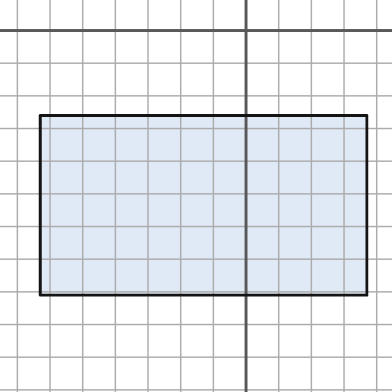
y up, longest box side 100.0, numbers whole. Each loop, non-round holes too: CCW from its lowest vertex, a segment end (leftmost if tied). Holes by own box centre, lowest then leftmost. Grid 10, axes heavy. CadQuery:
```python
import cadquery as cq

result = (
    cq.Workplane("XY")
    .moveTo(-63.0, -81.0)
    .lineTo(37.0, -81.0)
    .lineTo(37.0, -26.0)
    .lineTo(-63.0, -26.0)
    .close()
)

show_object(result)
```